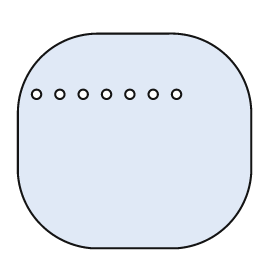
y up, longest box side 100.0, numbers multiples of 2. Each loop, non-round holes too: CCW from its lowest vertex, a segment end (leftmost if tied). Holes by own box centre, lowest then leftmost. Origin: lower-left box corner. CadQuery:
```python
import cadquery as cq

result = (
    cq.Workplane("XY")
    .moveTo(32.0, 0.0)
    .lineTo(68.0, 0.0)
    .threePointArc((90.0, 10.0), (100.0, 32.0))
    .lineTo(100.0, 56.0)
    .threePointArc((90.0, 82.0), (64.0, 92.0))
    .lineTo(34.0, 92.0)
    .threePointArc((10.0, 82.0), (0.0, 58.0))
    .lineTo(0.0, 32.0)
    .threePointArc((10.0, 10.0), (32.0, 0.0))
    .close()
    .moveTo(8.0, 66.0)
    .circle(2.0)
    .moveTo(18.0, 66.0)
    .circle(2.0)
    .moveTo(28.0, 66.0)
    .circle(2.0)
    .moveTo(38.0, 66.0)
    .circle(2.0)
    .moveTo(48.0, 66.0)
    .circle(2.0)
    .moveTo(58.0, 66.0)
    .circle(2.0)
    .moveTo(68.0, 66.0)
    .circle(2.0)
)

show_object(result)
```